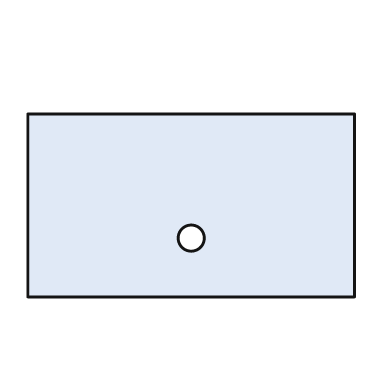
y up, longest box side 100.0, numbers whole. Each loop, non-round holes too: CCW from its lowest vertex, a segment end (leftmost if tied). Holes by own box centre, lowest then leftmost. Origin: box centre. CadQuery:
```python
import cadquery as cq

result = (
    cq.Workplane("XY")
    .moveTo(-50.0, -28.0)
    .lineTo(50.0, -28.0)
    .lineTo(50.0, 28.0)
    .lineTo(-50.0, 28.0)
    .close()
    .moveTo(0.0, -10.0)
    .circle(4.0)
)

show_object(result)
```